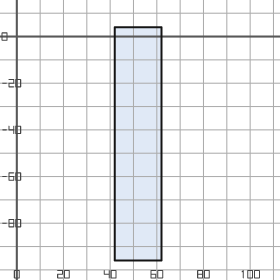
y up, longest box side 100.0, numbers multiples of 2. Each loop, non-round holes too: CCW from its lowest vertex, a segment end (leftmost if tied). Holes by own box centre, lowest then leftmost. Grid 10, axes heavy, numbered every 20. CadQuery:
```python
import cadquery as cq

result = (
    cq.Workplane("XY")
    .moveTo(42.0, -96.0)
    .lineTo(62.0, -96.0)
    .lineTo(62.0, 4.0)
    .lineTo(42.0, 4.0)
    .close()
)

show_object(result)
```